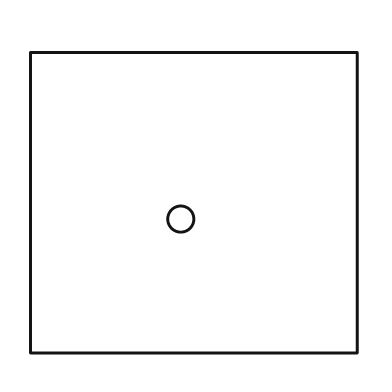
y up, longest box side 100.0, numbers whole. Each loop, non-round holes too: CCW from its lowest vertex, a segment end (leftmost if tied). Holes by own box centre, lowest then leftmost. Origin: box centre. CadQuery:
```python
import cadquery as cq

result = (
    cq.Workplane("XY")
    .moveTo(-50.0, -46.0)
    .lineTo(50.0, -46.0)
    .lineTo(50.0, 46.0)
    .lineTo(-50.0, 46.0)
    .close()
    .moveTo(-4.0, -5.0)
    .circle(4.0)
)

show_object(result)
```